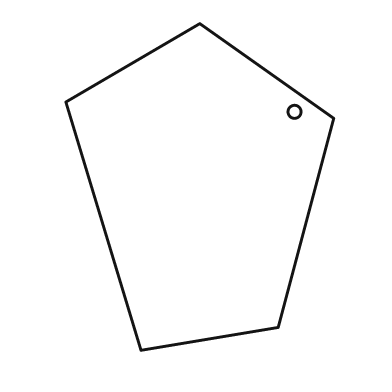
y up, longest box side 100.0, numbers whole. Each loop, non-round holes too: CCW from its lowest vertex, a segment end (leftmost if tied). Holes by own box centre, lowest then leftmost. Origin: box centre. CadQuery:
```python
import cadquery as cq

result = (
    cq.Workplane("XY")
    .moveTo(-18.0, -50.0)
    .lineTo(24.0, -43.0)
    .lineTo(41.0, 21.0)
    .lineTo(0.0, 50.0)
    .lineTo(-41.0, 26.0)
    .close()
    .moveTo(29.0, 23.0)
    .circle(2.0)
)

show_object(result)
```